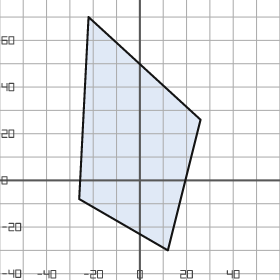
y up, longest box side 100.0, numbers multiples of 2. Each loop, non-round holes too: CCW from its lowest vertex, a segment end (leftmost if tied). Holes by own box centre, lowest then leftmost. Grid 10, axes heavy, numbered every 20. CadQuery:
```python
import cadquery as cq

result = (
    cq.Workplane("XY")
    .moveTo(12.0, -30.0)
    .lineTo(26.0, 26.0)
    .lineTo(-22.0, 70.0)
    .lineTo(-26.0, -8.0)
    .close()
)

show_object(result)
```